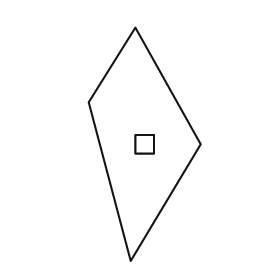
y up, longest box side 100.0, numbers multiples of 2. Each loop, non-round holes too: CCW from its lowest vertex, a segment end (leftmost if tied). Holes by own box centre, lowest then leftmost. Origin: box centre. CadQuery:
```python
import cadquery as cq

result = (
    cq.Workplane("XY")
    .moveTo(-6.0, -50.0)
    .lineTo(24.0, 0.0)
    .lineTo(-4.0, 50.0)
    .lineTo(-24.0, 18.0)
    .close()
    .moveTo(-4.0, -4.0)
    .lineTo(4.0, -4.0)
    .lineTo(4.0, 4.0)
    .lineTo(-4.0, 4.0)
    .close()
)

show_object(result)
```